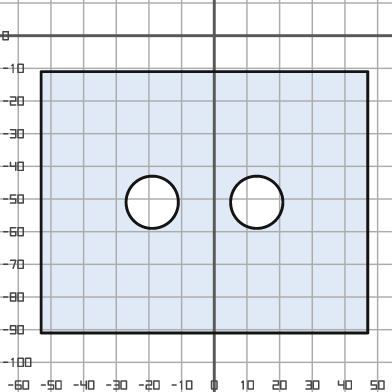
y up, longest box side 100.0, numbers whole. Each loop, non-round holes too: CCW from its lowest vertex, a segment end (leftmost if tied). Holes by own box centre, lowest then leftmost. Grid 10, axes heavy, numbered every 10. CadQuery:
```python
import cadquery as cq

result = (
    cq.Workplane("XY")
    .moveTo(-53.0, -91.0)
    .lineTo(47.0, -91.0)
    .lineTo(47.0, -11.0)
    .lineTo(-53.0, -11.0)
    .close()
    .moveTo(-19.0, -51.0)
    .circle(8.0)
    .moveTo(13.0, -51.0)
    .circle(8.0)
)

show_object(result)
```